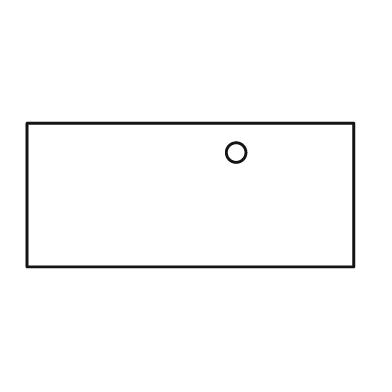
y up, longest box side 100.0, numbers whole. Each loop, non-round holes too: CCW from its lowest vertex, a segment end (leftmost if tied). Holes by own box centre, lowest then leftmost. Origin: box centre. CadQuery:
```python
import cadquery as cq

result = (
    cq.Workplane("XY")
    .moveTo(-50.0, -22.0)
    .lineTo(50.0, -22.0)
    .lineTo(50.0, 22.0)
    .lineTo(-50.0, 22.0)
    .close()
    .moveTo(14.0, 13.0)
    .circle(3.0)
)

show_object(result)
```